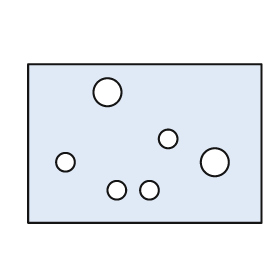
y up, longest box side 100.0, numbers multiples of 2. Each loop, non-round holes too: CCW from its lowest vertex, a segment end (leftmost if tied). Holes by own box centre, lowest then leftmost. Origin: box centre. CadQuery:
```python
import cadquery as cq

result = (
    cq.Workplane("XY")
    .moveTo(-50.0, -34.0)
    .lineTo(50.0, -34.0)
    .lineTo(50.0, 34.0)
    .lineTo(-50.0, 34.0)
    .close()
    .moveTo(-12.0, -20.0)
    .circle(4.0)
    .moveTo(2.0, -20.0)
    .circle(4.0)
    .moveTo(-34.0, -8.0)
    .circle(4.0)
    .moveTo(30.0, -8.0)
    .circle(6.0)
    .moveTo(10.0, 2.0)
    .circle(4.0)
    .moveTo(-16.0, 22.0)
    .circle(6.0)
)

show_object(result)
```